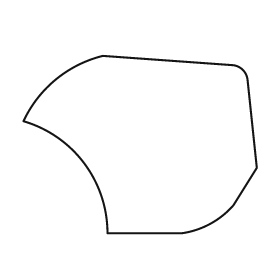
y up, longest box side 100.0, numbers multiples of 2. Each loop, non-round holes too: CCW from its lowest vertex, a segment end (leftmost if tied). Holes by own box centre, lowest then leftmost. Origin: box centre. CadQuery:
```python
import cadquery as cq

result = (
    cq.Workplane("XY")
    .moveTo(-14.0, -38.0)
    .lineTo(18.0, -38.0)
    .threePointArc((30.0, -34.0), (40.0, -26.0))
    .lineTo(50.0, -10.0)
    .lineTo(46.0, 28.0)
    .threePointArc((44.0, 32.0), (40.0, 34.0))
    .lineTo(-16.0, 38.0)
    .threePointArc((-36.0, 28.0), (-50.0, 10.0))
    .threePointArc((-24.0, -8.0), (-14.0, -38.0))
    .close()
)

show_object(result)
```